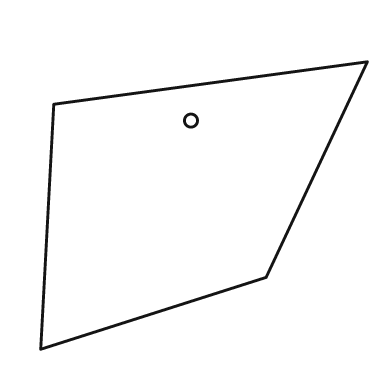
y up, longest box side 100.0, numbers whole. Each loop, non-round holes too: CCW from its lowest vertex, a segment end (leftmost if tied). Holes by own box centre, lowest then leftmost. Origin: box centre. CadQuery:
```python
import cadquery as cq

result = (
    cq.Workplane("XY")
    .moveTo(-50.0, -44.0)
    .lineTo(19.0, -22.0)
    .lineTo(50.0, 44.0)
    .lineTo(-46.0, 31.0)
    .close()
    .moveTo(-4.0, 26.0)
    .circle(2.0)
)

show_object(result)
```